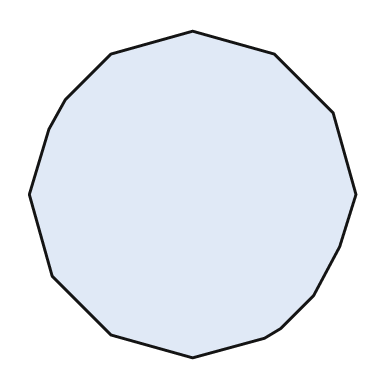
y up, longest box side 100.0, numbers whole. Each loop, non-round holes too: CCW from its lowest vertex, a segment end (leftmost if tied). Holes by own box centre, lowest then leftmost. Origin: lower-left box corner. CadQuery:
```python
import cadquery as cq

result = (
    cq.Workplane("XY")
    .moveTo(50.0, 0.0)
    .lineTo(72.0, 6.0)
    .lineTo(77.0, 9.0)
    .lineTo(87.0, 19.0)
    .lineTo(95.0, 34.0)
    .lineTo(100.0, 50.0)
    .lineTo(93.0, 75.0)
    .lineTo(75.0, 93.0)
    .lineTo(50.0, 100.0)
    .lineTo(25.0, 93.0)
    .lineTo(11.0, 79.0)
    .lineTo(6.0, 70.0)
    .lineTo(0.0, 50.0)
    .lineTo(7.0, 25.0)
    .lineTo(25.0, 7.0)
    .close()
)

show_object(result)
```